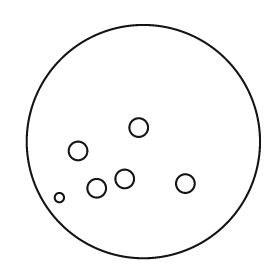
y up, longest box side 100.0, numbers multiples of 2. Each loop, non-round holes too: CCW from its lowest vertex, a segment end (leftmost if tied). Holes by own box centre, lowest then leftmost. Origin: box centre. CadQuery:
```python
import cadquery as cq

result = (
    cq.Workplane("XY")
    .moveTo(0.0, 0.0)
    .circle(50.0)
    .moveTo(-36.0, -24.0)
    .circle(2.0)
    .moveTo(-20.0, -20.0)
    .circle(4.0)
    .moveTo(18.0, -18.0)
    .circle(4.0)
    .moveTo(-8.0, -16.0)
    .circle(4.0)
    .moveTo(-28.0, -4.0)
    .circle(4.0)
    .moveTo(-2.0, 6.0)
    .circle(4.0)
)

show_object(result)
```